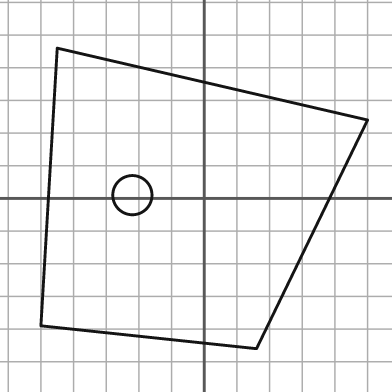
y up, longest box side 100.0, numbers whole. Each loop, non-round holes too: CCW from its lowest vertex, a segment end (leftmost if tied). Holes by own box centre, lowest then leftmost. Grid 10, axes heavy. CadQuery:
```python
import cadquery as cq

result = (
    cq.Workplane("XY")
    .moveTo(16.0, -46.0)
    .lineTo(50.0, 24.0)
    .lineTo(-45.0, 46.0)
    .lineTo(-50.0, -39.0)
    .close()
    .moveTo(-22.0, 1.0)
    .circle(6.0)
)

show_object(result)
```